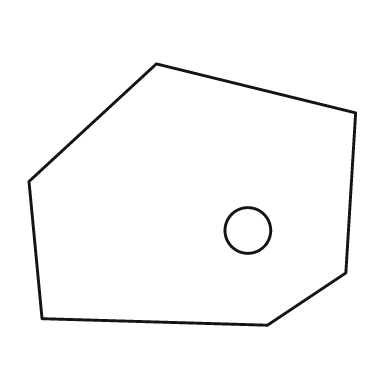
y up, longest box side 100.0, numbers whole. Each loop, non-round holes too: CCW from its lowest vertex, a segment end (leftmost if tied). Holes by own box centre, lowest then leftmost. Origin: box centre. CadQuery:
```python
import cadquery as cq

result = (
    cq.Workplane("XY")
    .moveTo(23.0, -40.0)
    .lineTo(47.0, -24.0)
    .lineTo(50.0, 25.0)
    .lineTo(-11.0, 40.0)
    .lineTo(-50.0, 4.0)
    .lineTo(-46.0, -38.0)
    .close()
    .moveTo(17.0, -11.0)
    .circle(7.0)
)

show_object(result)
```